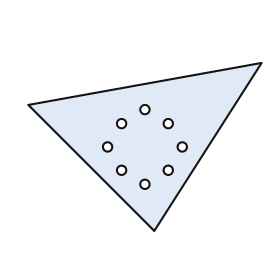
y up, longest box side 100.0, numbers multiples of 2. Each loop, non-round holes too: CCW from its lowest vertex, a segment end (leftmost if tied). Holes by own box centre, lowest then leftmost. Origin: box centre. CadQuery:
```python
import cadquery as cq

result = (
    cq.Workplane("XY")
    .moveTo(4.0, -36.0)
    .lineTo(50.0, 36.0)
    .lineTo(-50.0, 18.0)
    .close()
    .moveTo(0.0, -16.0)
    .circle(2.0)
    .moveTo(-10.0, -10.0)
    .circle(2.0)
    .moveTo(10.0, -10.0)
    .circle(2.0)
    .moveTo(-16.0, 0.0)
    .circle(2.0)
    .moveTo(16.0, 0.0)
    .circle(2.0)
    .moveTo(-10.0, 10.0)
    .circle(2.0)
    .moveTo(10.0, 10.0)
    .circle(2.0)
    .moveTo(0.0, 16.0)
    .circle(2.0)
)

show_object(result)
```